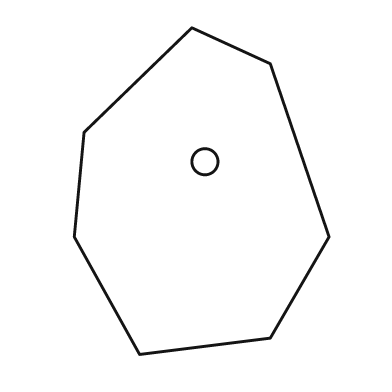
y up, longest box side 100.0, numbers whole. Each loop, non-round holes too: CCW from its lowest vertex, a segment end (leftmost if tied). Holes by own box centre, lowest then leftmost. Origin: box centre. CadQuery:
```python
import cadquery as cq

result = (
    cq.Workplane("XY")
    .moveTo(-19.0, -50.0)
    .lineTo(21.0, -45.0)
    .lineTo(39.0, -14.0)
    .lineTo(21.0, 39.0)
    .lineTo(-3.0, 50.0)
    .lineTo(-36.0, 18.0)
    .lineTo(-39.0, -14.0)
    .close()
    .moveTo(1.0, 9.0)
    .circle(4.0)
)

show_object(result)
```